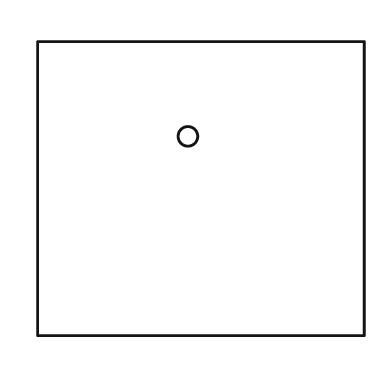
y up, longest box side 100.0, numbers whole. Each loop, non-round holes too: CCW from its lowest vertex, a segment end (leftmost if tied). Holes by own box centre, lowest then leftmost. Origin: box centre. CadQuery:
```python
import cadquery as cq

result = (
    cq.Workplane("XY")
    .moveTo(-50.0, -45.0)
    .lineTo(50.0, -45.0)
    .lineTo(50.0, 45.0)
    .lineTo(-50.0, 45.0)
    .close()
    .moveTo(-4.0, 16.0)
    .circle(3.0)
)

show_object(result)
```